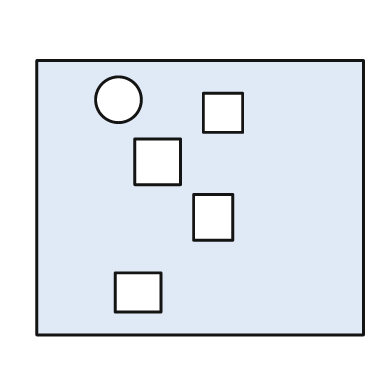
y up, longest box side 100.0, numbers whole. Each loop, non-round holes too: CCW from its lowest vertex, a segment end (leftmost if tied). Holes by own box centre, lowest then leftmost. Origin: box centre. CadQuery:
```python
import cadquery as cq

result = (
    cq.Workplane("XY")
    .moveTo(-50.0, -42.0)
    .lineTo(50.0, -42.0)
    .lineTo(50.0, 42.0)
    .lineTo(-50.0, 42.0)
    .close()
    .moveTo(-26.0, -35.0)
    .lineTo(-12.0, -35.0)
    .lineTo(-12.0, -23.0)
    .lineTo(-26.0, -23.0)
    .close()
    .moveTo(-2.0, -13.0)
    .lineTo(10.0, -13.0)
    .lineTo(10.0, 1.0)
    .lineTo(-2.0, 1.0)
    .close()
    .moveTo(-20.0, 4.0)
    .lineTo(-6.0, 4.0)
    .lineTo(-6.0, 18.0)
    .lineTo(-20.0, 18.0)
    .close()
    .moveTo(1.0, 20.0)
    .lineTo(13.0, 20.0)
    .lineTo(13.0, 32.0)
    .lineTo(1.0, 32.0)
    .close()
    .moveTo(-25.0, 30.0)
    .circle(7.0)
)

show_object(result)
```